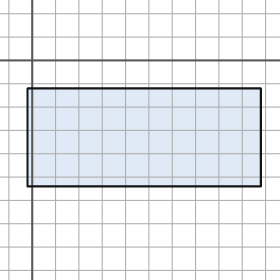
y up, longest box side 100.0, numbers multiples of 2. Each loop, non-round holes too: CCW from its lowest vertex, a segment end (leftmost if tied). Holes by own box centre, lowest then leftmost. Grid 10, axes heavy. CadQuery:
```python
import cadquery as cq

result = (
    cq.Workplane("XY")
    .moveTo(-2.0, -54.0)
    .lineTo(98.0, -54.0)
    .lineTo(98.0, -12.0)
    .lineTo(-2.0, -12.0)
    .close()
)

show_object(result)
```